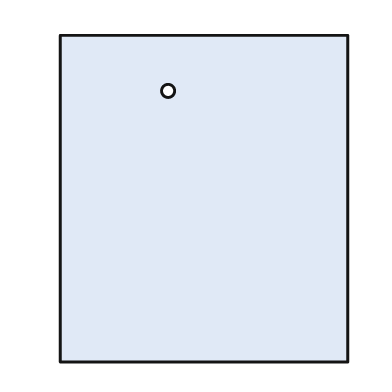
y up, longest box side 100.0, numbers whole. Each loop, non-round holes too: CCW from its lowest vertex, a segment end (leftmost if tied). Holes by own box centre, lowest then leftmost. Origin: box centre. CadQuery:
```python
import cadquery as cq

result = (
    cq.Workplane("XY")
    .moveTo(-44.0, -50.0)
    .lineTo(44.0, -50.0)
    .lineTo(44.0, 50.0)
    .lineTo(-44.0, 50.0)
    .close()
    .moveTo(-11.0, 33.0)
    .circle(2.0)
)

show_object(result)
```